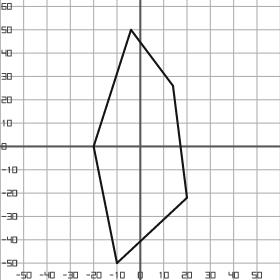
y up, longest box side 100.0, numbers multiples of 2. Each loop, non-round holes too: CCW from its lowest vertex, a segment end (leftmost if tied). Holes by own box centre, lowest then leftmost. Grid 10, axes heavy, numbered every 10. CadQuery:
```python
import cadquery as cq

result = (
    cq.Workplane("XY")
    .moveTo(-10.0, -50.0)
    .lineTo(20.0, -22.0)
    .lineTo(14.0, 26.0)
    .lineTo(-4.0, 50.0)
    .lineTo(-20.0, 0.0)
    .close()
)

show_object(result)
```